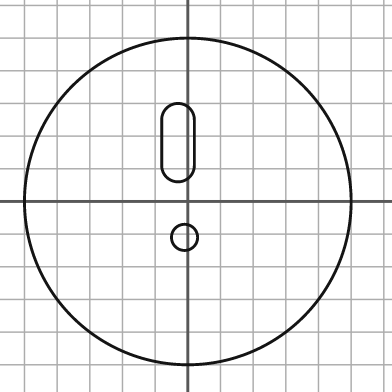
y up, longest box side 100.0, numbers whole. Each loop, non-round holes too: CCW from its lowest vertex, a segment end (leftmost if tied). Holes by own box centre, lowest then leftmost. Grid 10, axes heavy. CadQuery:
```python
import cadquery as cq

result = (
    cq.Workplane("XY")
    .moveTo(0.0, 0.0)
    .circle(50.0)
    .moveTo(-1.0, -11.0)
    .circle(4.0)
    .moveTo(-8.0, 11.0)
    .threePointArc((-3.0, 6.0), (2.0, 11.0))
    .lineTo(2.0, 25.0)
    .threePointArc((-3.0, 30.0), (-8.0, 25.0))
    .close()
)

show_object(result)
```